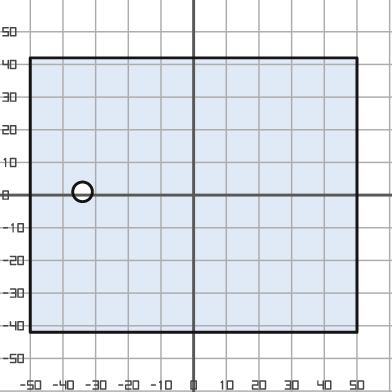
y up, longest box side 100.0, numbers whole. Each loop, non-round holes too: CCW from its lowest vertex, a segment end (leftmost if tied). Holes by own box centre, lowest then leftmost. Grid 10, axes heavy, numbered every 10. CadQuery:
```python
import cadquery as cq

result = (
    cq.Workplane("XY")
    .moveTo(-50.0, -42.0)
    .lineTo(50.0, -42.0)
    .lineTo(50.0, 42.0)
    .lineTo(-50.0, 42.0)
    .close()
    .moveTo(-34.0, 1.0)
    .circle(3.0)
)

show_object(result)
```